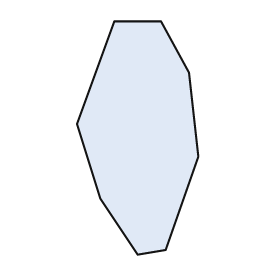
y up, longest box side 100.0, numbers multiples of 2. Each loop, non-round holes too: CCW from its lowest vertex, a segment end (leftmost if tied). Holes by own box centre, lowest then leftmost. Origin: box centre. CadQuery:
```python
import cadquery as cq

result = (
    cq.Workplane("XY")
    .moveTo(0.0, -50.0)
    .lineTo(12.0, -48.0)
    .lineTo(26.0, -8.0)
    .lineTo(22.0, 28.0)
    .lineTo(10.0, 50.0)
    .lineTo(-10.0, 50.0)
    .lineTo(-26.0, 6.0)
    .lineTo(-16.0, -26.0)
    .close()
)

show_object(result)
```